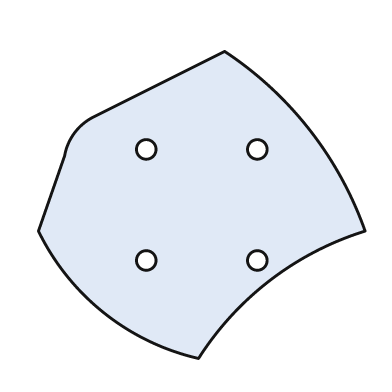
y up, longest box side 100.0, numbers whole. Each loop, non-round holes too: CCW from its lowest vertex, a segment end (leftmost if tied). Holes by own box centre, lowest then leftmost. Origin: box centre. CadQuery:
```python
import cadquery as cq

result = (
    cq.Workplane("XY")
    .moveTo(-1.0, -47.0)
    .threePointArc((21.0, -23.0), (50.0, -8.0))
    .threePointArc((33.0, 23.0), (7.0, 47.0))
    .lineTo(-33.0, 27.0)
    .threePointArc((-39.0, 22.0), (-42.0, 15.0))
    .lineTo(-50.0, -8.0)
    .threePointArc((-30.0, -33.0), (-1.0, -47.0))
    .close()
    .moveTo(-17.0, -17.0)
    .circle(3.0)
    .moveTo(17.0, -17.0)
    .circle(3.0)
    .moveTo(-17.0, 17.0)
    .circle(3.0)
    .moveTo(17.0, 17.0)
    .circle(3.0)
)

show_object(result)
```